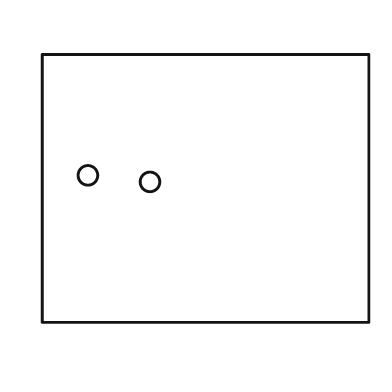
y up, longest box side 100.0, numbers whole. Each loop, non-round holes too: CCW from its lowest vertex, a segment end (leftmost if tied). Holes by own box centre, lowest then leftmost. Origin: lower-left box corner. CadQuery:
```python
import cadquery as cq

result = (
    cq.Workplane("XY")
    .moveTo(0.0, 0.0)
    .lineTo(100.0, 0.0)
    .lineTo(100.0, 82.0)
    .lineTo(0.0, 82.0)
    .close()
    .moveTo(33.0, 43.0)
    .circle(3.0)
    .moveTo(14.0, 45.0)
    .circle(3.0)
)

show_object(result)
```